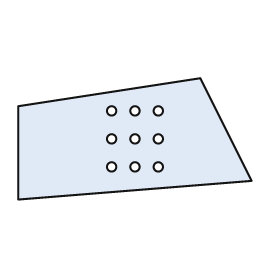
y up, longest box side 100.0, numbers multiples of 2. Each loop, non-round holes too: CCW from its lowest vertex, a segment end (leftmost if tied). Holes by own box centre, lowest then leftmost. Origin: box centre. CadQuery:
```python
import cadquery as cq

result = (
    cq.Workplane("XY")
    .moveTo(-50.0, -26.0)
    .lineTo(50.0, -18.0)
    .lineTo(28.0, 26.0)
    .lineTo(-50.0, 14.0)
    .close()
    .moveTo(-10.0, -12.0)
    .circle(2.0)
    .moveTo(0.0, -12.0)
    .circle(2.0)
    .moveTo(10.0, -12.0)
    .circle(2.0)
    .moveTo(-10.0, 0.0)
    .circle(2.0)
    .moveTo(0.0, 0.0)
    .circle(2.0)
    .moveTo(10.0, 0.0)
    .circle(2.0)
    .moveTo(-10.0, 12.0)
    .circle(2.0)
    .moveTo(0.0, 12.0)
    .circle(2.0)
    .moveTo(10.0, 12.0)
    .circle(2.0)
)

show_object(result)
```